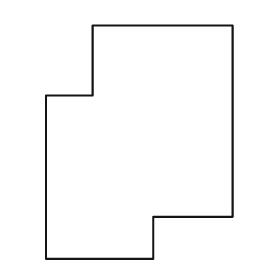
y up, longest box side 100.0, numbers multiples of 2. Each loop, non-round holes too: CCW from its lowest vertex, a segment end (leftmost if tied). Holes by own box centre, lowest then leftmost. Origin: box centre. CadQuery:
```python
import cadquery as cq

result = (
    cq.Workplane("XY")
    .moveTo(-40.0, -50.0)
    .lineTo(6.0, -50.0)
    .lineTo(6.0, -32.0)
    .lineTo(40.0, -32.0)
    .lineTo(40.0, 50.0)
    .lineTo(-20.0, 50.0)
    .lineTo(-20.0, 20.0)
    .lineTo(-40.0, 20.0)
    .close()
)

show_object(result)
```